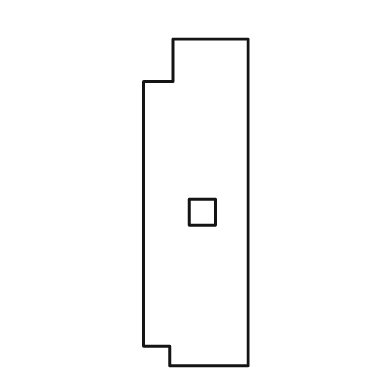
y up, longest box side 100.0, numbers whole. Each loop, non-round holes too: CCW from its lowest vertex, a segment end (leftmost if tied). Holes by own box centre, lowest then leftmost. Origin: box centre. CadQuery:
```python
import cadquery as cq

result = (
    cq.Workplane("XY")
    .moveTo(-8.0, -50.0)
    .lineTo(16.0, -50.0)
    .lineTo(16.0, 50.0)
    .lineTo(-7.0, 50.0)
    .lineTo(-7.0, 37.0)
    .lineTo(-16.0, 37.0)
    .lineTo(-16.0, -44.0)
    .lineTo(-8.0, -44.0)
    .close()
    .moveTo(-2.0, -7.0)
    .lineTo(6.0, -7.0)
    .lineTo(6.0, 1.0)
    .lineTo(-2.0, 1.0)
    .close()
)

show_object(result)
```